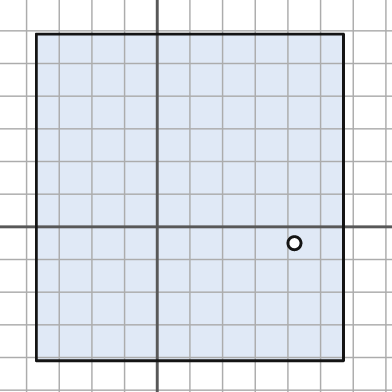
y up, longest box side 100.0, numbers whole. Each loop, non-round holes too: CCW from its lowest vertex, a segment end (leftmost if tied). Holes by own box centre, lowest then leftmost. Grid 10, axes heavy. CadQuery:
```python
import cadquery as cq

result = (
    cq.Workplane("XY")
    .moveTo(-37.0, -41.0)
    .lineTo(57.0, -41.0)
    .lineTo(57.0, 59.0)
    .lineTo(-37.0, 59.0)
    .close()
    .moveTo(42.0, -5.0)
    .circle(2.0)
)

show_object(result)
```